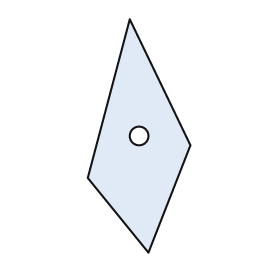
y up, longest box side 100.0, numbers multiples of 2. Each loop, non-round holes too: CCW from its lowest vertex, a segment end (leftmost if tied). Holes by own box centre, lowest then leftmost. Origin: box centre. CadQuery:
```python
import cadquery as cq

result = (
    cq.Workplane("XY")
    .moveTo(4.0, -50.0)
    .lineTo(22.0, -4.0)
    .lineTo(-4.0, 50.0)
    .lineTo(-22.0, -18.0)
    .close()
    .moveTo(0.0, 0.0)
    .circle(4.0)
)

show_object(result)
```